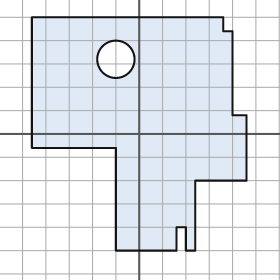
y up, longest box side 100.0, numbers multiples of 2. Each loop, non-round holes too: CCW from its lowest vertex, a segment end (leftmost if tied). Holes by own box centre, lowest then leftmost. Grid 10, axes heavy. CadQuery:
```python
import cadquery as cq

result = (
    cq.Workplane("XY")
    .moveTo(-10.0, -50.0)
    .lineTo(16.0, -50.0)
    .lineTo(16.0, -40.0)
    .lineTo(20.0, -40.0)
    .lineTo(20.0, -50.0)
    .lineTo(24.0, -50.0)
    .lineTo(24.0, -20.0)
    .lineTo(46.0, -20.0)
    .lineTo(46.0, 8.0)
    .lineTo(40.0, 8.0)
    .lineTo(40.0, 44.0)
    .lineTo(36.0, 44.0)
    .lineTo(36.0, 50.0)
    .lineTo(-46.0, 50.0)
    .lineTo(-46.0, -6.0)
    .lineTo(-10.0, -6.0)
    .close()
    .moveTo(-10.0, 32.0)
    .circle(8.0)
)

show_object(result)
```